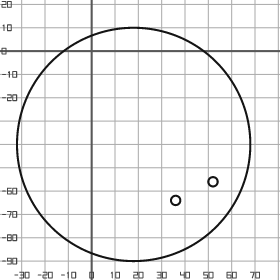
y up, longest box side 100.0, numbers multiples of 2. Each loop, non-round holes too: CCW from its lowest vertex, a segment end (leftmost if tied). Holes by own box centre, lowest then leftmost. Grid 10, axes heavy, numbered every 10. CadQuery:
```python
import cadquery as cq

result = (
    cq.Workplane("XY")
    .moveTo(18.0, -40.0)
    .circle(50.0)
    .moveTo(36.0, -64.0)
    .circle(2.0)
    .moveTo(52.0, -56.0)
    .circle(2.0)
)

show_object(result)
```